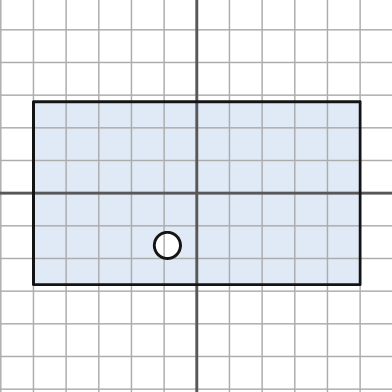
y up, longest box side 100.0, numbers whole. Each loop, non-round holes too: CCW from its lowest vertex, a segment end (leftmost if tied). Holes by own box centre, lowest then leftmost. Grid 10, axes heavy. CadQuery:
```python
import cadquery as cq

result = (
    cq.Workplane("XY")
    .moveTo(-50.0, -28.0)
    .lineTo(50.0, -28.0)
    .lineTo(50.0, 28.0)
    .lineTo(-50.0, 28.0)
    .close()
    .moveTo(-9.0, -16.0)
    .circle(4.0)
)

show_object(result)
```